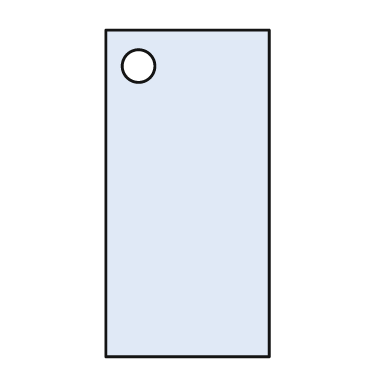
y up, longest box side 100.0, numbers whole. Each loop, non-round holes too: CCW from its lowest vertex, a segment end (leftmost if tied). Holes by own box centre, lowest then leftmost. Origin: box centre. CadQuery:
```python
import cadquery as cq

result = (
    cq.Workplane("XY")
    .moveTo(-25.0, -50.0)
    .lineTo(25.0, -50.0)
    .lineTo(25.0, 50.0)
    .lineTo(-25.0, 50.0)
    .close()
    .moveTo(-15.0, 39.0)
    .circle(5.0)
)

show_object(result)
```